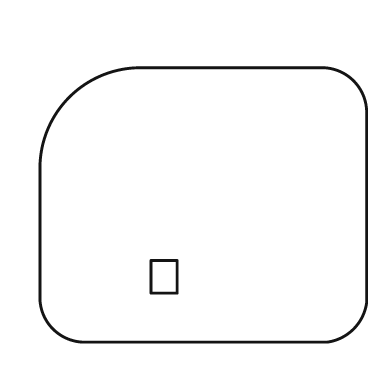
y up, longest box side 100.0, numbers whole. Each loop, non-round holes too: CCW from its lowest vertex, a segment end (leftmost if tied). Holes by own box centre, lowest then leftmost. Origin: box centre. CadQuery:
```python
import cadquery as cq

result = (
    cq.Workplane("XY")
    .moveTo(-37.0, -42.0)
    .lineTo(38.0, -42.0)
    .threePointArc((46.0, -38.0), (50.0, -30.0))
    .lineTo(50.0, 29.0)
    .threePointArc((46.0, 38.0), (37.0, 42.0))
    .lineTo(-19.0, 42.0)
    .threePointArc((-41.0, 33.0), (-50.0, 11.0))
    .lineTo(-50.0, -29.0)
    .threePointArc((-46.0, -38.0), (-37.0, -42.0))
    .close()
    .moveTo(-16.0, -27.0)
    .lineTo(-8.0, -27.0)
    .lineTo(-8.0, -17.0)
    .lineTo(-16.0, -17.0)
    .close()
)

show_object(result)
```